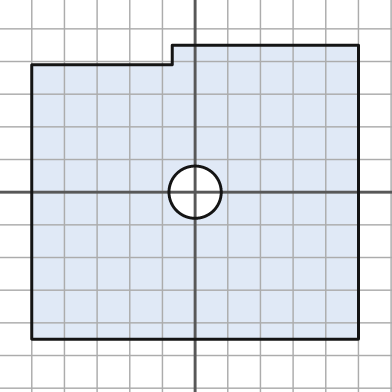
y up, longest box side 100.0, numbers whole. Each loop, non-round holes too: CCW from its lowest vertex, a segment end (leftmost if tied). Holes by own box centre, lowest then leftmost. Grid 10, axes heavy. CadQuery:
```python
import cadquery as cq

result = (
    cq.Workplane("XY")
    .moveTo(-50.0, -45.0)
    .lineTo(50.0, -45.0)
    .lineTo(50.0, 45.0)
    .lineTo(-7.0, 45.0)
    .lineTo(-7.0, 39.0)
    .lineTo(-50.0, 39.0)
    .close()
    .moveTo(0.0, 0.0)
    .circle(8.0)
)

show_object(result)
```